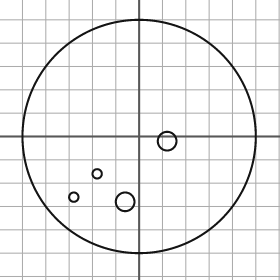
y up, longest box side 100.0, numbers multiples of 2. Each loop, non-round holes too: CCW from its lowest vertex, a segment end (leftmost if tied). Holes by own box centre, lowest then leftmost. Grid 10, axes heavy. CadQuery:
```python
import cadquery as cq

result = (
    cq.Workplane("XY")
    .moveTo(0.0, 0.0)
    .circle(50.0)
    .moveTo(-6.0, -28.0)
    .circle(4.0)
    .moveTo(-28.0, -26.0)
    .circle(2.0)
    .moveTo(-18.0, -16.0)
    .circle(2.0)
    .moveTo(12.0, -2.0)
    .circle(4.0)
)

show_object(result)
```